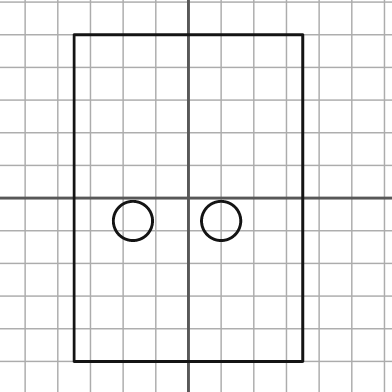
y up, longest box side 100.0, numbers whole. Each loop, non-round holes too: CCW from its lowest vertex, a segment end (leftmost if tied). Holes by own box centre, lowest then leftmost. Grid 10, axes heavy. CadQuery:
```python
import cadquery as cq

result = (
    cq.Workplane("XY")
    .moveTo(-35.0, -50.0)
    .lineTo(35.0, -50.0)
    .lineTo(35.0, 50.0)
    .lineTo(-35.0, 50.0)
    .close()
    .moveTo(-17.0, -7.0)
    .circle(6.0)
    .moveTo(10.0, -7.0)
    .circle(6.0)
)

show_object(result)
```